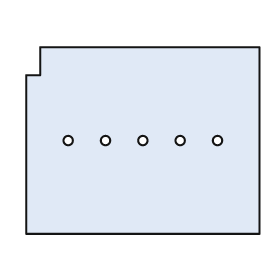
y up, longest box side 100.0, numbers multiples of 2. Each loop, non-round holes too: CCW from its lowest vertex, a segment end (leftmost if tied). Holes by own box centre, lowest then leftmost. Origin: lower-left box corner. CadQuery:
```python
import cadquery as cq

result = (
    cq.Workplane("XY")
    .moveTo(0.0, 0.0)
    .lineTo(100.0, 0.0)
    .lineTo(100.0, 80.0)
    .lineTo(6.0, 80.0)
    .lineTo(6.0, 68.0)
    .lineTo(0.0, 68.0)
    .close()
    .moveTo(18.0, 40.0)
    .circle(2.0)
    .moveTo(34.0, 40.0)
    .circle(2.0)
    .moveTo(50.0, 40.0)
    .circle(2.0)
    .moveTo(66.0, 40.0)
    .circle(2.0)
    .moveTo(82.0, 40.0)
    .circle(2.0)
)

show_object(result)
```